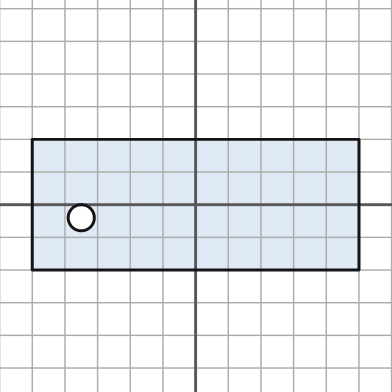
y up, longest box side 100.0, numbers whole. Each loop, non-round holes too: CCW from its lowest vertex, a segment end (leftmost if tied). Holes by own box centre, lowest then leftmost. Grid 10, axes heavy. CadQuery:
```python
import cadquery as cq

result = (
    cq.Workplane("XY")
    .moveTo(-50.0, -20.0)
    .lineTo(50.0, -20.0)
    .lineTo(50.0, 20.0)
    .lineTo(-50.0, 20.0)
    .close()
    .moveTo(-35.0, -4.0)
    .circle(4.0)
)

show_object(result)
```